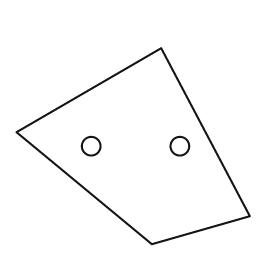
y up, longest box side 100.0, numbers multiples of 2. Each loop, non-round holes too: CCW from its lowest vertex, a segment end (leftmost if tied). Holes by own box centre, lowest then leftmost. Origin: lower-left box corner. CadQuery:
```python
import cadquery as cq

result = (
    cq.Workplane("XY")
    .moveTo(58.0, 0.0)
    .lineTo(100.0, 12.0)
    .lineTo(62.0, 84.0)
    .lineTo(0.0, 48.0)
    .close()
    .moveTo(32.0, 42.0)
    .circle(4.0)
    .moveTo(70.0, 42.0)
    .circle(4.0)
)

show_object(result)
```